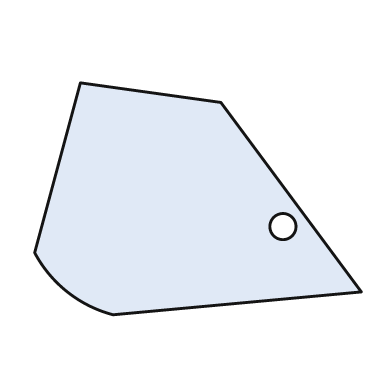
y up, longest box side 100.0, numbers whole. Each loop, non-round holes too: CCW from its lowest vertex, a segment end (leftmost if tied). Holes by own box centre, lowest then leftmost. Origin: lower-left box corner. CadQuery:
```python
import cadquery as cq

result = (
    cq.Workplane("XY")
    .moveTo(24.0, 0.0)
    .lineTo(100.0, 7.0)
    .lineTo(57.0, 65.0)
    .lineTo(14.0, 71.0)
    .lineTo(0.0, 19.0)
    .threePointArc((10.0, 7.0), (24.0, 0.0))
    .close()
    .moveTo(76.0, 27.0)
    .circle(4.0)
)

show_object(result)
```